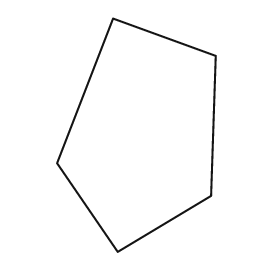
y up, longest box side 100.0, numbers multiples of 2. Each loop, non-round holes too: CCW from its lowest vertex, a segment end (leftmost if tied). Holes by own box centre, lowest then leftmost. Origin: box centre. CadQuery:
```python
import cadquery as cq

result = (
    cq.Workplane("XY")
    .moveTo(-8.0, -50.0)
    .lineTo(32.0, -26.0)
    .lineTo(34.0, 34.0)
    .lineTo(-10.0, 50.0)
    .lineTo(-34.0, -12.0)
    .close()
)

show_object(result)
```